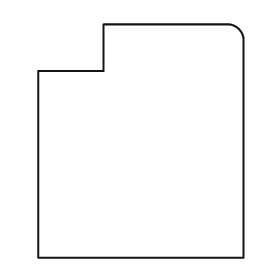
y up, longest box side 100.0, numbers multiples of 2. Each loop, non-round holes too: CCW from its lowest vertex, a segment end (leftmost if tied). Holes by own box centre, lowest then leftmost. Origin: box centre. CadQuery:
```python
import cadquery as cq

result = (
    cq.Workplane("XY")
    .moveTo(-44.0, -50.0)
    .lineTo(44.0, -50.0)
    .lineTo(44.0, 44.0)
    .threePointArc((42.0, 48.0), (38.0, 50.0))
    .lineTo(-16.0, 50.0)
    .lineTo(-16.0, 30.0)
    .lineTo(-44.0, 30.0)
    .close()
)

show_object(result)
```